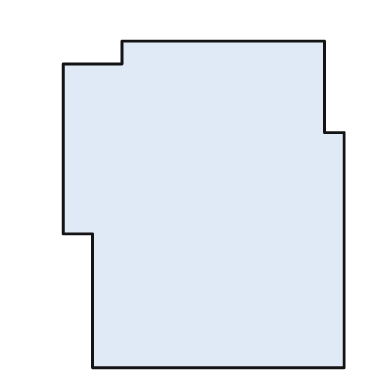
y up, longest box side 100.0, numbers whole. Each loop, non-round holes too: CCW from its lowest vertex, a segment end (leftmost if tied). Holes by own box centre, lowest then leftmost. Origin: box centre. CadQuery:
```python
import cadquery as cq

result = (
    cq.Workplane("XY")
    .moveTo(-34.0, -50.0)
    .lineTo(43.0, -50.0)
    .lineTo(43.0, 22.0)
    .lineTo(37.0, 22.0)
    .lineTo(37.0, 50.0)
    .lineTo(-25.0, 50.0)
    .lineTo(-25.0, 43.0)
    .lineTo(-43.0, 43.0)
    .lineTo(-43.0, -9.0)
    .lineTo(-34.0, -9.0)
    .close()
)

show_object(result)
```